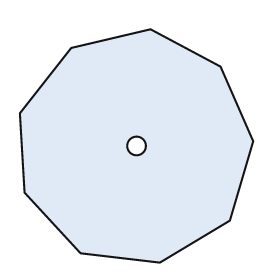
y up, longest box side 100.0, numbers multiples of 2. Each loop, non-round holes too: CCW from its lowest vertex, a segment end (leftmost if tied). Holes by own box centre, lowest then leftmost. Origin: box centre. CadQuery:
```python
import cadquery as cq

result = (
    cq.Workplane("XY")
    .moveTo(10.0, -50.0)
    .lineTo(40.0, -32.0)
    .lineTo(50.0, 2.0)
    .lineTo(36.0, 34.0)
    .lineTo(6.0, 50.0)
    .lineTo(-28.0, 42.0)
    .lineTo(-50.0, 14.0)
    .lineTo(-48.0, -20.0)
    .lineTo(-24.0, -46.0)
    .close()
    .moveTo(0.0, 0.0)
    .circle(4.0)
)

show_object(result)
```